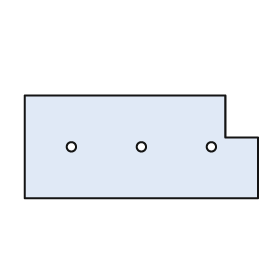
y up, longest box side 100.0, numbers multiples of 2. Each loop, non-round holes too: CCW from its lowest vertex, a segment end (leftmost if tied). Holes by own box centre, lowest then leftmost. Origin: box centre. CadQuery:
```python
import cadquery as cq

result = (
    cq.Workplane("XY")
    .moveTo(-50.0, -22.0)
    .lineTo(50.0, -22.0)
    .lineTo(50.0, 4.0)
    .lineTo(36.0, 4.0)
    .lineTo(36.0, 22.0)
    .lineTo(-50.0, 22.0)
    .close()
    .moveTo(-30.0, 0.0)
    .circle(2.0)
    .moveTo(0.0, 0.0)
    .circle(2.0)
    .moveTo(30.0, 0.0)
    .circle(2.0)
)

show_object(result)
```